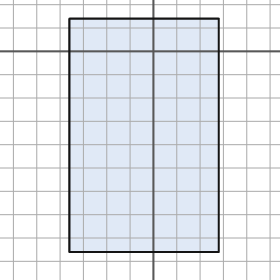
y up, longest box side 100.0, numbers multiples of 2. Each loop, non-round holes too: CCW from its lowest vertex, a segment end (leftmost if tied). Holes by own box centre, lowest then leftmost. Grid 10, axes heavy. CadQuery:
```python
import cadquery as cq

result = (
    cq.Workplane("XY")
    .moveTo(-36.0, -86.0)
    .lineTo(28.0, -86.0)
    .lineTo(28.0, 14.0)
    .lineTo(-36.0, 14.0)
    .close()
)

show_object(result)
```